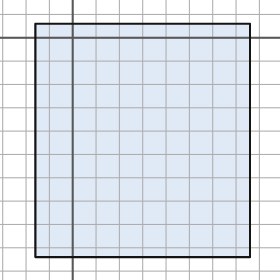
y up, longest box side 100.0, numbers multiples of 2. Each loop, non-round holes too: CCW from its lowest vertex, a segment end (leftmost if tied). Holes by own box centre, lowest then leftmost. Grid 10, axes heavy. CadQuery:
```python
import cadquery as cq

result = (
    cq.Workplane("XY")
    .moveTo(-16.0, -94.0)
    .lineTo(76.0, -94.0)
    .lineTo(76.0, 6.0)
    .lineTo(-16.0, 6.0)
    .close()
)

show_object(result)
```